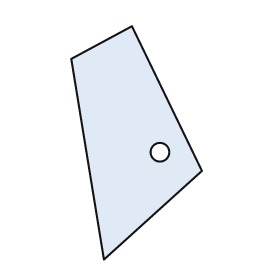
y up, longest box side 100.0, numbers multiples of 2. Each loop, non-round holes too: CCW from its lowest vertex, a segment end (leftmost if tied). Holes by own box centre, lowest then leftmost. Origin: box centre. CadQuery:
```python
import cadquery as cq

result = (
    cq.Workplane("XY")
    .moveTo(-14.0, -50.0)
    .lineTo(28.0, -12.0)
    .lineTo(-2.0, 50.0)
    .lineTo(-28.0, 36.0)
    .close()
    .moveTo(10.0, -4.0)
    .circle(4.0)
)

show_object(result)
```